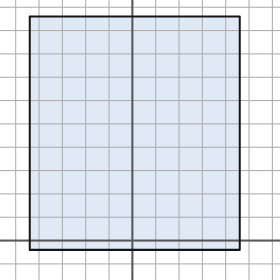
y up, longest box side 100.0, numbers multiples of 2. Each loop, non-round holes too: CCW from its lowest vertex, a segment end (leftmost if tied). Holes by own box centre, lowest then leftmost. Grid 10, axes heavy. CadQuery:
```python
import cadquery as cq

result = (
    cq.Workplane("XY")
    .moveTo(-44.0, -4.0)
    .lineTo(46.0, -4.0)
    .lineTo(46.0, 96.0)
    .lineTo(-44.0, 96.0)
    .close()
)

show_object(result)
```